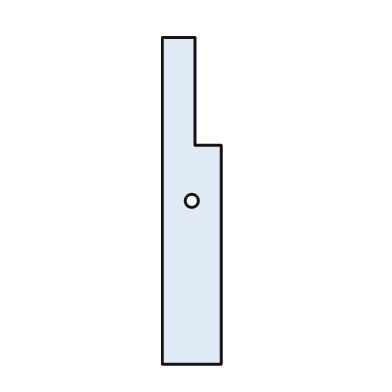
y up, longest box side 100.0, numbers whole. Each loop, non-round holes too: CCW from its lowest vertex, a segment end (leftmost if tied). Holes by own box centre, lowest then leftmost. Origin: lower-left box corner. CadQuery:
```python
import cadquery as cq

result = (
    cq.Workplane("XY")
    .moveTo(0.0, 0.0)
    .lineTo(18.0, 0.0)
    .lineTo(18.0, 67.0)
    .lineTo(10.0, 67.0)
    .lineTo(10.0, 100.0)
    .lineTo(0.0, 100.0)
    .close()
    .moveTo(9.0, 50.0)
    .circle(2.0)
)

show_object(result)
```